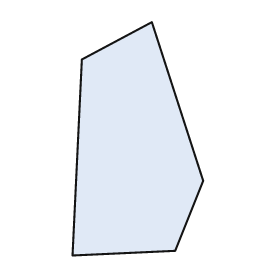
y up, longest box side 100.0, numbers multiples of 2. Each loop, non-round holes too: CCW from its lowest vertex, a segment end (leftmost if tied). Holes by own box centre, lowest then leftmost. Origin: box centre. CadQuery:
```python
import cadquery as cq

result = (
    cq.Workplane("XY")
    .moveTo(-28.0, -50.0)
    .lineTo(16.0, -48.0)
    .lineTo(28.0, -18.0)
    .lineTo(6.0, 50.0)
    .lineTo(-24.0, 34.0)
    .close()
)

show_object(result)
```